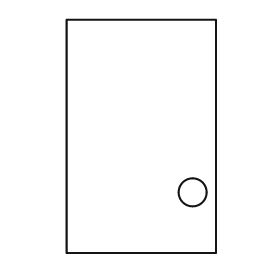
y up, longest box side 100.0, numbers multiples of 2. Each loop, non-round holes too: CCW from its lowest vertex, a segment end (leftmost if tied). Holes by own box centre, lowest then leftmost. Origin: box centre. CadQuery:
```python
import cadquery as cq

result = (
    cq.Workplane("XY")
    .moveTo(-32.0, -50.0)
    .lineTo(32.0, -50.0)
    .lineTo(32.0, 50.0)
    .lineTo(-32.0, 50.0)
    .close()
    .moveTo(22.0, -24.0)
    .circle(6.0)
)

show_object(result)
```